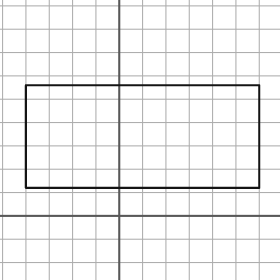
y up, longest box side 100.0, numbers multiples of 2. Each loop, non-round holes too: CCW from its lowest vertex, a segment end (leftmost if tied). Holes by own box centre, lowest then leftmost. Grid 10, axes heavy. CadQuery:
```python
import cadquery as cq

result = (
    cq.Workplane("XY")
    .moveTo(-40.0, 12.0)
    .lineTo(60.0, 12.0)
    .lineTo(60.0, 56.0)
    .lineTo(-40.0, 56.0)
    .close()
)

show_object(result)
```